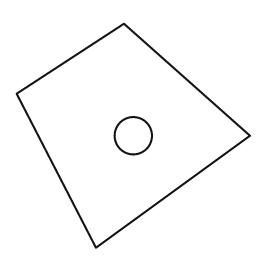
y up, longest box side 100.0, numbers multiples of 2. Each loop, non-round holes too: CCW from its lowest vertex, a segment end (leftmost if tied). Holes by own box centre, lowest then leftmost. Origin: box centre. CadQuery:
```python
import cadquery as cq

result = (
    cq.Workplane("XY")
    .moveTo(-16.0, -48.0)
    .lineTo(50.0, 0.0)
    .lineTo(-4.0, 48.0)
    .lineTo(-50.0, 18.0)
    .close()
    .moveTo(0.0, 0.0)
    .circle(8.0)
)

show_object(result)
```